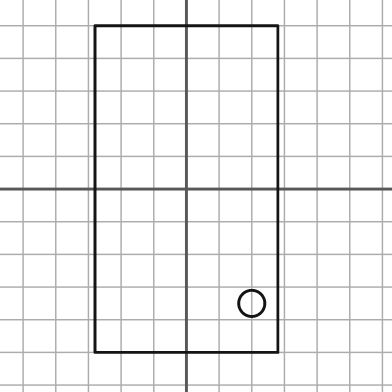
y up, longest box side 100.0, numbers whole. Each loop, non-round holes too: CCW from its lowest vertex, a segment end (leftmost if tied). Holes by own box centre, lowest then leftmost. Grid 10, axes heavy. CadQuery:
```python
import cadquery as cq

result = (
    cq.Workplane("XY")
    .moveTo(-28.0, -50.0)
    .lineTo(28.0, -50.0)
    .lineTo(28.0, 50.0)
    .lineTo(-28.0, 50.0)
    .close()
    .moveTo(20.0, -35.0)
    .circle(4.0)
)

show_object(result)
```